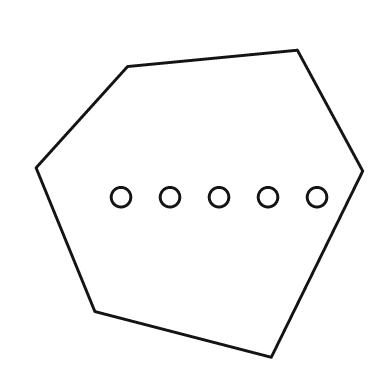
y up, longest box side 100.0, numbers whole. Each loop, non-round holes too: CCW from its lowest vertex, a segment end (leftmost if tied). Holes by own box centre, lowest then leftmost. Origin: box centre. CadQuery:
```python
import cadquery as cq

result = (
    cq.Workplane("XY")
    .moveTo(22.0, -47.0)
    .lineTo(50.0, 10.0)
    .lineTo(30.0, 47.0)
    .lineTo(-22.0, 42.0)
    .lineTo(-50.0, 11.0)
    .lineTo(-32.0, -33.0)
    .close()
    .moveTo(-24.0, 2.0)
    .circle(3.0)
    .moveTo(-9.0, 2.0)
    .circle(3.0)
    .moveTo(6.0, 2.0)
    .circle(3.0)
    .moveTo(21.0, 2.0)
    .circle(3.0)
    .moveTo(36.0, 2.0)
    .circle(3.0)
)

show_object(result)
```